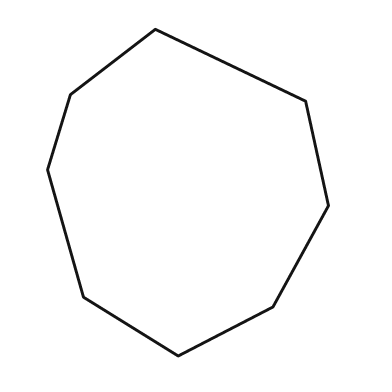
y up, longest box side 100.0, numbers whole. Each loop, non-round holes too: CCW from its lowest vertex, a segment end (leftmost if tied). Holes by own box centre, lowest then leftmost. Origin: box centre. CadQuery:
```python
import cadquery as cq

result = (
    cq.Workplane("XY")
    .moveTo(-3.0, -50.0)
    .lineTo(26.0, -35.0)
    .lineTo(43.0, -4.0)
    .lineTo(36.0, 28.0)
    .lineTo(-10.0, 50.0)
    .lineTo(-36.0, 30.0)
    .lineTo(-43.0, 7.0)
    .lineTo(-32.0, -32.0)
    .close()
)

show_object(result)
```